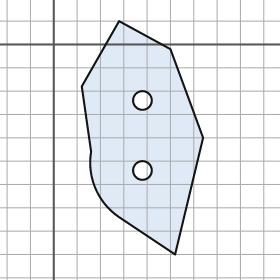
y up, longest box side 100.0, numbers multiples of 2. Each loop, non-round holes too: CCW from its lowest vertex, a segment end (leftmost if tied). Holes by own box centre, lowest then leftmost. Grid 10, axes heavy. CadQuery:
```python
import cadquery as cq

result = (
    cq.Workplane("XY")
    .moveTo(52.0, -90.0)
    .lineTo(64.0, -40.0)
    .lineTo(50.0, -2.0)
    .lineTo(28.0, 10.0)
    .lineTo(12.0, -18.0)
    .lineTo(16.0, -46.0)
    .threePointArc((18.0, -62.0), (28.0, -74.0))
    .close()
    .moveTo(38.0, -54.0)
    .circle(4.0)
    .moveTo(38.0, -24.0)
    .circle(4.0)
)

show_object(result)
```